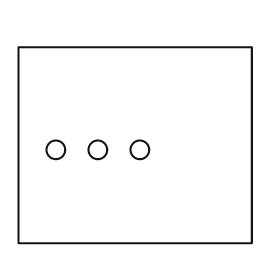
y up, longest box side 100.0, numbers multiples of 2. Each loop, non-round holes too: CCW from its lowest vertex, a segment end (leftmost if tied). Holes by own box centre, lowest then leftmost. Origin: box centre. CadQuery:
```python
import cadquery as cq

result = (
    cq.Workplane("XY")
    .moveTo(-50.0, -42.0)
    .lineTo(50.0, -42.0)
    .lineTo(50.0, 42.0)
    .lineTo(-50.0, 42.0)
    .close()
    .moveTo(-34.0, -2.0)
    .circle(4.0)
    .moveTo(-16.0, -2.0)
    .circle(4.0)
    .moveTo(2.0, -2.0)
    .circle(4.0)
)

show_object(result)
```